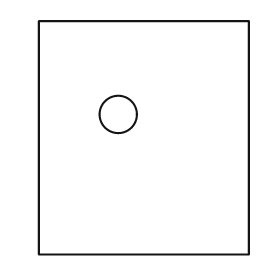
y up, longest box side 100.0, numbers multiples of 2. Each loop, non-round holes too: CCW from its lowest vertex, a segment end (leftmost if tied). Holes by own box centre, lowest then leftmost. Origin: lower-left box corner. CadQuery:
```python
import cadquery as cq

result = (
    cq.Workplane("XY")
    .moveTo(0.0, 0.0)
    .lineTo(90.0, 0.0)
    .lineTo(90.0, 100.0)
    .lineTo(0.0, 100.0)
    .close()
    .moveTo(34.0, 60.0)
    .circle(8.0)
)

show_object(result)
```